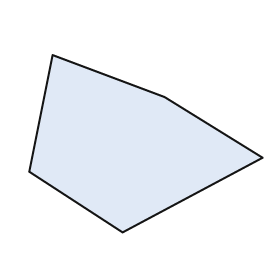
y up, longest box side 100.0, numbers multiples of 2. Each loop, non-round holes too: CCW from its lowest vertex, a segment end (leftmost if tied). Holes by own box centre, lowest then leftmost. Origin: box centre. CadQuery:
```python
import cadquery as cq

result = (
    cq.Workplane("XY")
    .moveTo(-10.0, -38.0)
    .lineTo(50.0, -6.0)
    .lineTo(8.0, 20.0)
    .lineTo(-40.0, 38.0)
    .lineTo(-50.0, -12.0)
    .close()
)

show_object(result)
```